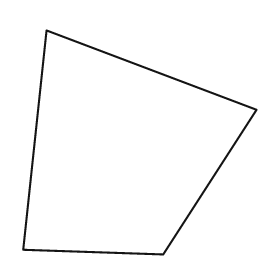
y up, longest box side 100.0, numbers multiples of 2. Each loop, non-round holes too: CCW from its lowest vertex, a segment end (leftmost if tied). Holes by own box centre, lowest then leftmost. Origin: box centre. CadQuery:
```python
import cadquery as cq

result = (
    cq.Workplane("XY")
    .moveTo(10.0, -48.0)
    .lineTo(50.0, 14.0)
    .lineTo(-40.0, 48.0)
    .lineTo(-50.0, -46.0)
    .close()
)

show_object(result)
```